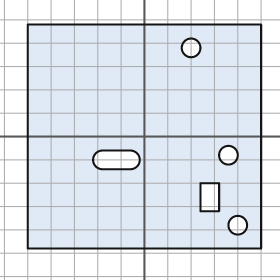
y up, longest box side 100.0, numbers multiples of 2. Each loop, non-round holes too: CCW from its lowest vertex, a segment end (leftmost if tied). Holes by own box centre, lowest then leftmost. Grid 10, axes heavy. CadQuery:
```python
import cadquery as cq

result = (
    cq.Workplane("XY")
    .moveTo(-50.0, -48.0)
    .lineTo(50.0, -48.0)
    .lineTo(50.0, 48.0)
    .lineTo(-50.0, 48.0)
    .close()
    .moveTo(40.0, -38.0)
    .circle(4.0)
    .moveTo(24.0, -32.0)
    .lineTo(32.0, -32.0)
    .lineTo(32.0, -20.0)
    .lineTo(24.0, -20.0)
    .close()
    .moveTo(-18.0, -14.0)
    .lineTo(-6.0, -14.0)
    .threePointArc((-2.0, -10.0), (-6.0, -6.0))
    .lineTo(-18.0, -6.0)
    .threePointArc((-22.0, -10.0), (-18.0, -14.0))
    .close()
    .moveTo(36.0, -8.0)
    .circle(4.0)
    .moveTo(20.0, 38.0)
    .circle(4.0)
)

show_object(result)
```